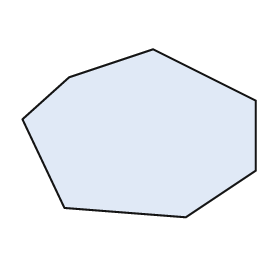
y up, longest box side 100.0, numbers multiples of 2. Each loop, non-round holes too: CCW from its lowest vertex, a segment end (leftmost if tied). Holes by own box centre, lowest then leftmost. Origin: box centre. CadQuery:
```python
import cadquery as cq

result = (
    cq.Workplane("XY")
    .moveTo(20.0, -36.0)
    .lineTo(50.0, -16.0)
    .lineTo(50.0, 14.0)
    .lineTo(6.0, 36.0)
    .lineTo(-30.0, 24.0)
    .lineTo(-50.0, 6.0)
    .lineTo(-32.0, -32.0)
    .close()
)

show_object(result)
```